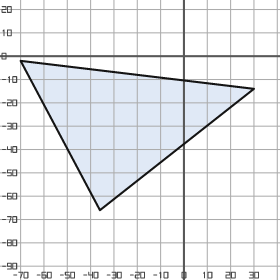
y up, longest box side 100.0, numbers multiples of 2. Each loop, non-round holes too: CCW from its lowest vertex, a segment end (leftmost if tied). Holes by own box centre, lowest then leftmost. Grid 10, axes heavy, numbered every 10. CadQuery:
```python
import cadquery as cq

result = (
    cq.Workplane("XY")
    .moveTo(-36.0, -66.0)
    .lineTo(30.0, -14.0)
    .lineTo(-70.0, -2.0)
    .close()
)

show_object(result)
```